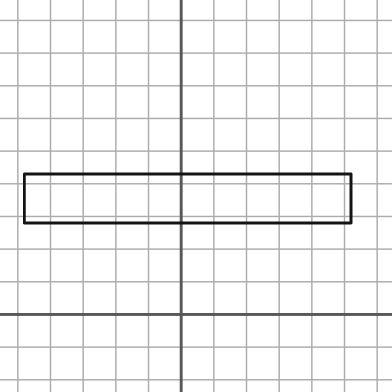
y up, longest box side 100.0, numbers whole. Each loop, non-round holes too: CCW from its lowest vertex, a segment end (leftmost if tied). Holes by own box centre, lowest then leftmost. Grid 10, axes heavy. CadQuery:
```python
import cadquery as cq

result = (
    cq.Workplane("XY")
    .moveTo(-48.0, 28.0)
    .lineTo(52.0, 28.0)
    .lineTo(52.0, 43.0)
    .lineTo(-48.0, 43.0)
    .close()
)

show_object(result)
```